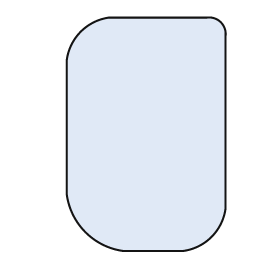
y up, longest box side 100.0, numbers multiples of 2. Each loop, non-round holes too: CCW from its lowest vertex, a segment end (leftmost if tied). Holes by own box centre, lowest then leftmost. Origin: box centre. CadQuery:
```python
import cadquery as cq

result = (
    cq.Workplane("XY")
    .moveTo(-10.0, -50.0)
    .lineTo(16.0, -50.0)
    .threePointArc((28.0, -44.0), (34.0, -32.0))
    .lineTo(34.0, 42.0)
    .threePointArc((32.0, 48.0), (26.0, 50.0))
    .lineTo(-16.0, 50.0)
    .threePointArc((-28.0, 44.0), (-34.0, 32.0))
    .lineTo(-34.0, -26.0)
    .threePointArc((-26.0, -42.0), (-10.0, -50.0))
    .close()
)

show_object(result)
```